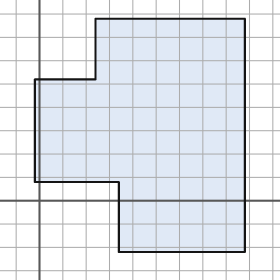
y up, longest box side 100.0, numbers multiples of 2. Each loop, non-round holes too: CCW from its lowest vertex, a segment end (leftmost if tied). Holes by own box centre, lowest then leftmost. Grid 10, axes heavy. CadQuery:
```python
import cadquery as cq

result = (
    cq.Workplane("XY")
    .moveTo(34.0, -22.0)
    .lineTo(88.0, -22.0)
    .lineTo(88.0, 78.0)
    .lineTo(24.0, 78.0)
    .lineTo(24.0, 52.0)
    .lineTo(-2.0, 52.0)
    .lineTo(-2.0, 8.0)
    .lineTo(34.0, 8.0)
    .close()
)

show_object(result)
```